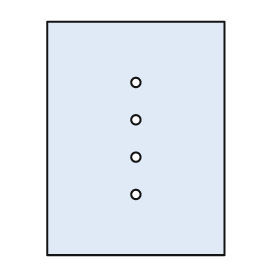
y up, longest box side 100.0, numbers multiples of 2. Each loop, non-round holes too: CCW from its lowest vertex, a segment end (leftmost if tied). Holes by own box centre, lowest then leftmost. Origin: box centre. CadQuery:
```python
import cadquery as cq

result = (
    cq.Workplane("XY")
    .moveTo(-38.0, -50.0)
    .lineTo(38.0, -50.0)
    .lineTo(38.0, 50.0)
    .lineTo(-38.0, 50.0)
    .close()
    .moveTo(0.0, -24.0)
    .circle(2.0)
    .moveTo(0.0, -8.0)
    .circle(2.0)
    .moveTo(0.0, 8.0)
    .circle(2.0)
    .moveTo(0.0, 24.0)
    .circle(2.0)
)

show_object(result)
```